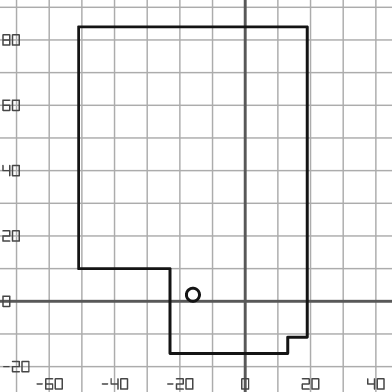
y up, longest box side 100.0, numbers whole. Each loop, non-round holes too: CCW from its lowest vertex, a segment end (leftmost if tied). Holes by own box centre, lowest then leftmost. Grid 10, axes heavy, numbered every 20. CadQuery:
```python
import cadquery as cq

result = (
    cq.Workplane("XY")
    .moveTo(-23.0, -16.0)
    .lineTo(13.0, -16.0)
    .lineTo(13.0, -11.0)
    .lineTo(19.0, -11.0)
    .lineTo(19.0, 84.0)
    .lineTo(-51.0, 84.0)
    .lineTo(-51.0, 10.0)
    .lineTo(-23.0, 10.0)
    .close()
    .moveTo(-16.0, 2.0)
    .circle(2.0)
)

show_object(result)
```